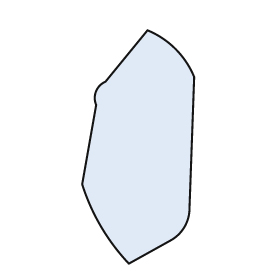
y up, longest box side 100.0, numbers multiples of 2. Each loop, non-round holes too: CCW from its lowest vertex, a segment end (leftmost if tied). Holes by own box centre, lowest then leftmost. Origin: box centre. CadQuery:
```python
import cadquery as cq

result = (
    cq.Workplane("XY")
    .moveTo(-4.0, -50.0)
    .lineTo(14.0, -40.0)
    .threePointArc((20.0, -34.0), (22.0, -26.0))
    .lineTo(24.0, 30.0)
    .threePointArc((16.0, 42.0), (4.0, 50.0))
    .lineTo(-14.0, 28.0)
    .threePointArc((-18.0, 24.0), (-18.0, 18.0))
    .lineTo(-24.0, -16.0)
    .threePointArc((-16.0, -34.0), (-4.0, -50.0))
    .close()
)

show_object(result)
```